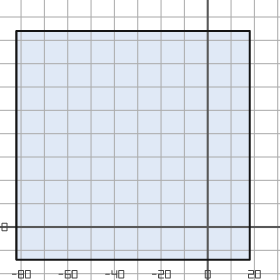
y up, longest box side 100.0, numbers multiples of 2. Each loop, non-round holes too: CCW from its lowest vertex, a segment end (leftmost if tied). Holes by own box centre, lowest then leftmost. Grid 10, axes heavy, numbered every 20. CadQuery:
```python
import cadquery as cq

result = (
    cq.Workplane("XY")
    .moveTo(-82.0, -14.0)
    .lineTo(18.0, -14.0)
    .lineTo(18.0, 84.0)
    .lineTo(-82.0, 84.0)
    .close()
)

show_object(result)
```